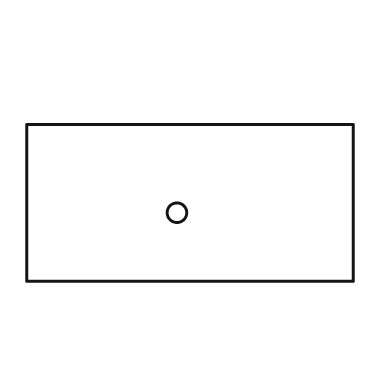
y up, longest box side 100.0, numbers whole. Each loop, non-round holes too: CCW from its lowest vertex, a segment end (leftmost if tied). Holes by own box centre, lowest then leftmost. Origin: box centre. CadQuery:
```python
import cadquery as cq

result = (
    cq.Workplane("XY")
    .moveTo(-50.0, -24.0)
    .lineTo(50.0, -24.0)
    .lineTo(50.0, 24.0)
    .lineTo(-50.0, 24.0)
    .close()
    .moveTo(-4.0, -3.0)
    .circle(3.0)
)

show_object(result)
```